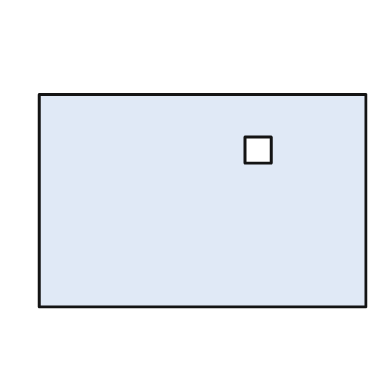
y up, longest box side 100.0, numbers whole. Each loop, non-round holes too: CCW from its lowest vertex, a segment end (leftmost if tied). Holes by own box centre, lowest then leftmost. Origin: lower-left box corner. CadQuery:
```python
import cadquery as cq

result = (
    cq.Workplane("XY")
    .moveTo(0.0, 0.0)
    .lineTo(100.0, 0.0)
    .lineTo(100.0, 65.0)
    .lineTo(0.0, 65.0)
    .close()
    .moveTo(63.0, 44.0)
    .lineTo(71.0, 44.0)
    .lineTo(71.0, 52.0)
    .lineTo(63.0, 52.0)
    .close()
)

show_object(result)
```